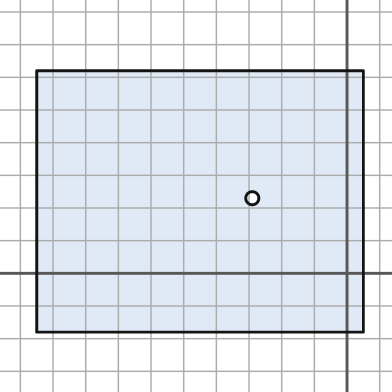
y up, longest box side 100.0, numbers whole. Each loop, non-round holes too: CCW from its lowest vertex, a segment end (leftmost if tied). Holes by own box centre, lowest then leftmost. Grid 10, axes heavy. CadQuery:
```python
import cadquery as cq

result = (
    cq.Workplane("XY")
    .moveTo(-95.0, -18.0)
    .lineTo(5.0, -18.0)
    .lineTo(5.0, 62.0)
    .lineTo(-95.0, 62.0)
    .close()
    .moveTo(-29.0, 23.0)
    .circle(2.0)
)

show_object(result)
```